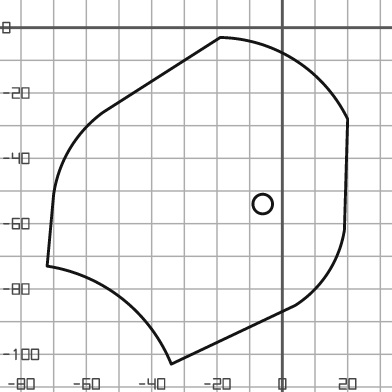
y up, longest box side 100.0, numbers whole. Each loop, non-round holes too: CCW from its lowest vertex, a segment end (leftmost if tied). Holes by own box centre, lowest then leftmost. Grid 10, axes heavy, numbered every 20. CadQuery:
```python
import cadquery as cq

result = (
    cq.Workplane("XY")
    .moveTo(-34.0, -103.0)
    .lineTo(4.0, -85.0)
    .threePointArc((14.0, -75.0), (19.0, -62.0))
    .lineTo(20.0, -28.0)
    .threePointArc((4.0, -10.0), (-19.0, -3.0))
    .lineTo(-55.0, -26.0)
    .threePointArc((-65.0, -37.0), (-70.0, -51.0))
    .lineTo(-72.0, -73.0)
    .threePointArc((-49.0, -83.0), (-34.0, -103.0))
    .close()
    .moveTo(-6.0, -54.0)
    .circle(3.0)
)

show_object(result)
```